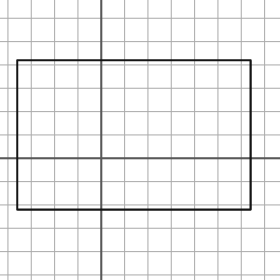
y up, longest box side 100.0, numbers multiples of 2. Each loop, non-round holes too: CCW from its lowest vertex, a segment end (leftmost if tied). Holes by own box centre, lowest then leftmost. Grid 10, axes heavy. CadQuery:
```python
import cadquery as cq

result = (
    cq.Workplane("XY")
    .moveTo(-36.0, -22.0)
    .lineTo(64.0, -22.0)
    .lineTo(64.0, 42.0)
    .lineTo(-36.0, 42.0)
    .close()
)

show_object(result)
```